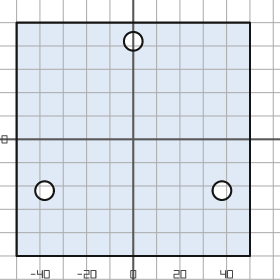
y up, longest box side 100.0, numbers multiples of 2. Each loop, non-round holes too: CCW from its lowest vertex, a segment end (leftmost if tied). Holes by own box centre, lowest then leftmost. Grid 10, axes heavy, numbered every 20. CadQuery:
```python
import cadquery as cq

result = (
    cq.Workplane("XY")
    .moveTo(-50.0, -50.0)
    .lineTo(50.0, -50.0)
    .lineTo(50.0, 50.0)
    .lineTo(-50.0, 50.0)
    .close()
    .moveTo(-38.0, -22.0)
    .circle(4.0)
    .moveTo(38.0, -22.0)
    .circle(4.0)
    .moveTo(0.0, 42.0)
    .circle(4.0)
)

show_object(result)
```